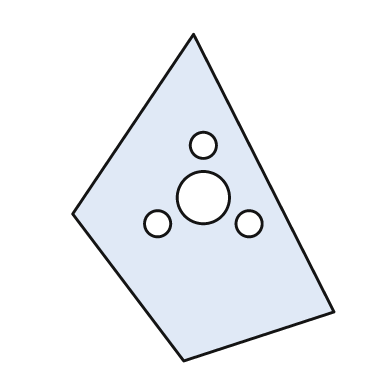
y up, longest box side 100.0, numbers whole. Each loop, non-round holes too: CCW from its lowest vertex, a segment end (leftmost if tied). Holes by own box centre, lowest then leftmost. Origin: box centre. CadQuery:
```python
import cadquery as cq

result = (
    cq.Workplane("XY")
    .moveTo(-6.0, -50.0)
    .lineTo(40.0, -35.0)
    .lineTo(-3.0, 50.0)
    .lineTo(-40.0, -5.0)
    .close()
    .moveTo(-14.0, -8.0)
    .circle(4.0)
    .moveTo(14.0, -8.0)
    .circle(4.0)
    .moveTo(0.0, 0.0)
    .circle(8.0)
    .moveTo(0.0, 16.0)
    .circle(4.0)
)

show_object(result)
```